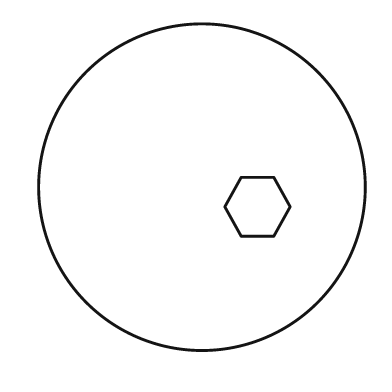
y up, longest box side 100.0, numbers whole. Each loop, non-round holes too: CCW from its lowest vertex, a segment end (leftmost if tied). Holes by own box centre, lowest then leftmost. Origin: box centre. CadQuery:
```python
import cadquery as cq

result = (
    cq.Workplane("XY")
    .moveTo(0.0, 0.0)
    .circle(50.0)
    .moveTo(12.0, -15.0)
    .lineTo(22.0, -15.0)
    .lineTo(27.0, -6.0)
    .lineTo(22.0, 3.0)
    .lineTo(12.0, 3.0)
    .lineTo(7.0, -6.0)
    .close()
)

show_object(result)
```